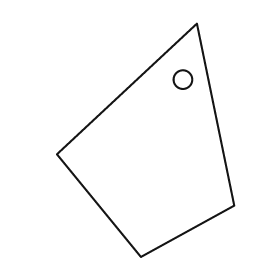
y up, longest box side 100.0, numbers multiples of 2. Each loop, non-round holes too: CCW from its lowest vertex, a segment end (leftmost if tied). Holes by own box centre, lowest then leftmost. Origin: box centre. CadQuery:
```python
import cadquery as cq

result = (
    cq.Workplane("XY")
    .moveTo(-2.0, -50.0)
    .lineTo(38.0, -28.0)
    .lineTo(22.0, 50.0)
    .lineTo(-38.0, -6.0)
    .close()
    .moveTo(16.0, 26.0)
    .circle(4.0)
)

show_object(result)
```